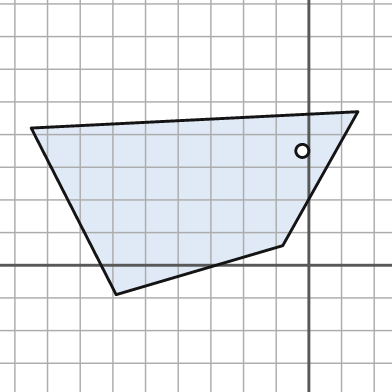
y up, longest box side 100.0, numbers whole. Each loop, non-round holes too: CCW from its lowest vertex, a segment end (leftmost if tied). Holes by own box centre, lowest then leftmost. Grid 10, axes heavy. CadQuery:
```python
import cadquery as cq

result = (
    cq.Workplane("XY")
    .moveTo(-59.0, -9.0)
    .lineTo(-8.0, 6.0)
    .lineTo(15.0, 47.0)
    .lineTo(-85.0, 42.0)
    .close()
    .moveTo(-2.0, 35.0)
    .circle(2.0)
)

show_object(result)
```